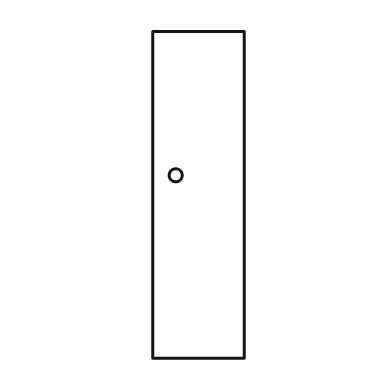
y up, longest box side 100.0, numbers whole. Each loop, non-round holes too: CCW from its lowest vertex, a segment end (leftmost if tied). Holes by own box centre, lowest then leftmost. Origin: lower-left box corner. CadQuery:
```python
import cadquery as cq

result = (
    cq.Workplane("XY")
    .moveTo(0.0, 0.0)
    .lineTo(28.0, 0.0)
    .lineTo(28.0, 100.0)
    .lineTo(0.0, 100.0)
    .close()
    .moveTo(7.0, 56.0)
    .circle(2.0)
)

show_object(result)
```